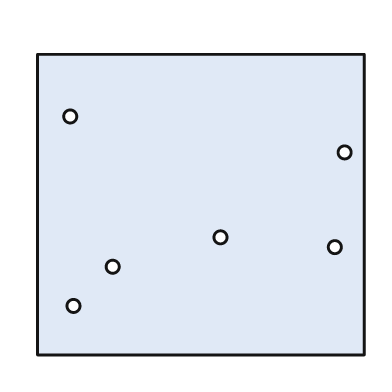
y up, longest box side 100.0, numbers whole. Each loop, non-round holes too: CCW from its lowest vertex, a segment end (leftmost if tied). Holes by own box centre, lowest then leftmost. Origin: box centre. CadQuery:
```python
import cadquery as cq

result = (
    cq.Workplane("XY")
    .moveTo(-50.0, -46.0)
    .lineTo(50.0, -46.0)
    .lineTo(50.0, 46.0)
    .lineTo(-50.0, 46.0)
    .close()
    .moveTo(-39.0, -31.0)
    .circle(2.0)
    .moveTo(-27.0, -19.0)
    .circle(2.0)
    .moveTo(41.0, -13.0)
    .circle(2.0)
    .moveTo(6.0, -10.0)
    .circle(2.0)
    .moveTo(44.0, 16.0)
    .circle(2.0)
    .moveTo(-40.0, 27.0)
    .circle(2.0)
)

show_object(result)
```